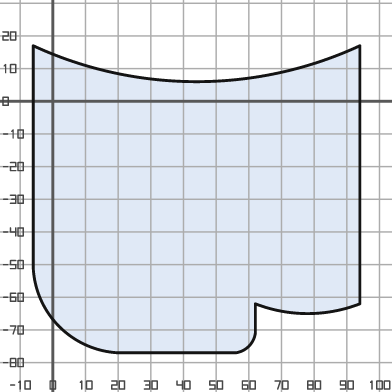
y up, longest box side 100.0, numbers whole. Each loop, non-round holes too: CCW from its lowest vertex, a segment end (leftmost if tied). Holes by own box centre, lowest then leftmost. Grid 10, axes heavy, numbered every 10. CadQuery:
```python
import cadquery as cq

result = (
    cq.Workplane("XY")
    .moveTo(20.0, -77.0)
    .lineTo(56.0, -77.0)
    .threePointArc((60.0, -75.0), (62.0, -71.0))
    .lineTo(62.0, -62.0)
    .threePointArc((78.0, -65.0), (94.0, -62.0))
    .lineTo(94.0, 17.0)
    .threePointArc((44.0, 6.0), (-6.0, 17.0))
    .lineTo(-6.0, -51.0)
    .threePointArc((2.0, -69.0), (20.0, -77.0))
    .close()
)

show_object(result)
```